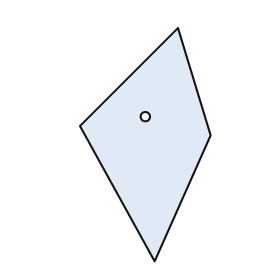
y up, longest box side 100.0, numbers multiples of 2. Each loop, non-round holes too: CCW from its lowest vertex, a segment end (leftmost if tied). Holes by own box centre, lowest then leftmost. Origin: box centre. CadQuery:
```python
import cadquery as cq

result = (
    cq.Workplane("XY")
    .moveTo(4.0, -50.0)
    .lineTo(28.0, 4.0)
    .lineTo(14.0, 50.0)
    .lineTo(-28.0, 8.0)
    .close()
    .moveTo(0.0, 12.0)
    .circle(2.0)
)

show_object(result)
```